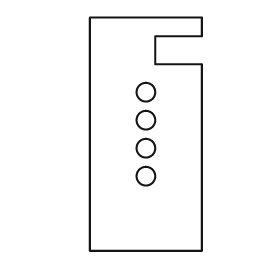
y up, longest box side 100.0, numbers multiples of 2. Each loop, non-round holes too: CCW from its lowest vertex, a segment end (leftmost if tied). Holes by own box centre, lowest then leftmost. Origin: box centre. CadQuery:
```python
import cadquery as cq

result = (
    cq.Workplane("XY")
    .moveTo(-24.0, -50.0)
    .lineTo(24.0, -50.0)
    .lineTo(24.0, 30.0)
    .lineTo(4.0, 30.0)
    .lineTo(4.0, 42.0)
    .lineTo(24.0, 42.0)
    .lineTo(24.0, 50.0)
    .lineTo(-24.0, 50.0)
    .close()
    .moveTo(0.0, -18.0)
    .circle(4.0)
    .moveTo(0.0, -6.0)
    .circle(4.0)
    .moveTo(0.0, 6.0)
    .circle(4.0)
    .moveTo(0.0, 18.0)
    .circle(4.0)
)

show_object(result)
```